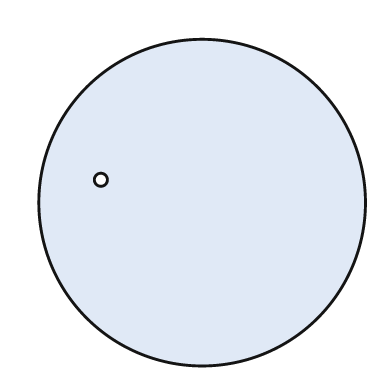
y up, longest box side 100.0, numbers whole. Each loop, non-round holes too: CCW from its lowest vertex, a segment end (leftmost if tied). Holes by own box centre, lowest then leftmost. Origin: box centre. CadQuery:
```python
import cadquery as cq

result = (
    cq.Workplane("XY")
    .moveTo(0.0, 0.0)
    .circle(50.0)
    .moveTo(-31.0, 7.0)
    .circle(2.0)
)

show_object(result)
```